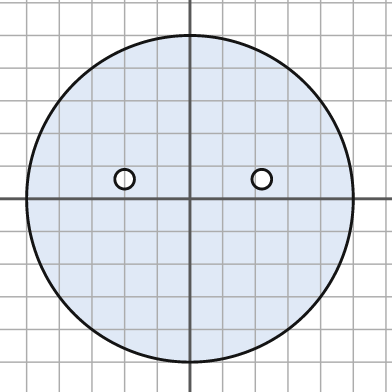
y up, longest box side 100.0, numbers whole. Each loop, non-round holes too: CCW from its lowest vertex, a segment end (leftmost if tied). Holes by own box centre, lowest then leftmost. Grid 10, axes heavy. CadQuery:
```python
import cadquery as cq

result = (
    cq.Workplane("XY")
    .moveTo(0.0, 0.0)
    .circle(50.0)
    .moveTo(-20.0, 6.0)
    .circle(3.0)
    .moveTo(22.0, 6.0)
    .circle(3.0)
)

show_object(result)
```